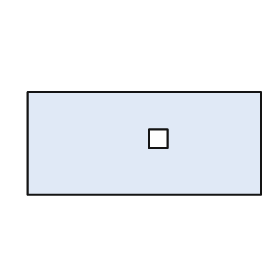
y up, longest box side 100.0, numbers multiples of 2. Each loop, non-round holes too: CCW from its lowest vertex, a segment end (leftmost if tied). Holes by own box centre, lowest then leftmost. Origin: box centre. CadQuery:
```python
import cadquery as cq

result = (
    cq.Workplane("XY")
    .moveTo(-50.0, -22.0)
    .lineTo(50.0, -22.0)
    .lineTo(50.0, 22.0)
    .lineTo(-50.0, 22.0)
    .close()
    .moveTo(2.0, -2.0)
    .lineTo(10.0, -2.0)
    .lineTo(10.0, 6.0)
    .lineTo(2.0, 6.0)
    .close()
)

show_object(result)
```